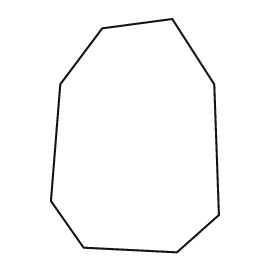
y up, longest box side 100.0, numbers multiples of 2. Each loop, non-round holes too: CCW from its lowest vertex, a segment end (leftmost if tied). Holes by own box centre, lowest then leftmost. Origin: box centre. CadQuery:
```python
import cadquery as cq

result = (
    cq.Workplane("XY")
    .moveTo(18.0, -50.0)
    .lineTo(36.0, -34.0)
    .lineTo(34.0, 22.0)
    .lineTo(16.0, 50.0)
    .lineTo(-14.0, 46.0)
    .lineTo(-32.0, 22.0)
    .lineTo(-36.0, -28.0)
    .lineTo(-22.0, -48.0)
    .close()
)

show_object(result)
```